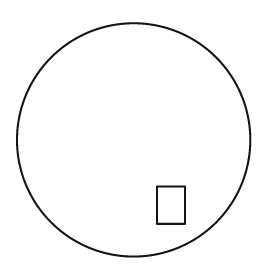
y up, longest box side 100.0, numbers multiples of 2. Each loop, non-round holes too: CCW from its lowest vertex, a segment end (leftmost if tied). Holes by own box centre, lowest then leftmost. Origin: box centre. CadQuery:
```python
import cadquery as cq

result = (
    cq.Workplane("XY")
    .moveTo(0.0, 0.0)
    .circle(50.0)
    .moveTo(10.0, -36.0)
    .lineTo(22.0, -36.0)
    .lineTo(22.0, -20.0)
    .lineTo(10.0, -20.0)
    .close()
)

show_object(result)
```